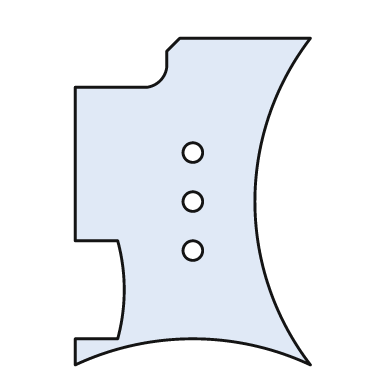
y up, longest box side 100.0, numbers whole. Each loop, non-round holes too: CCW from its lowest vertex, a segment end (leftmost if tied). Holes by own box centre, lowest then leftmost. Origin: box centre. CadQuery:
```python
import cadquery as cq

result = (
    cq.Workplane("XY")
    .moveTo(-36.0, -50.0)
    .threePointArc((0.0, -42.0), (36.0, -50.0))
    .threePointArc((19.0, 0.0), (36.0, 50.0))
    .lineTo(-4.0, 50.0)
    .lineTo(-8.0, 46.0)
    .lineTo(-8.0, 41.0)
    .threePointArc((-10.0, 37.0), (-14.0, 35.0))
    .lineTo(-36.0, 35.0)
    .lineTo(-36.0, -12.0)
    .lineTo(-23.0, -12.0)
    .threePointArc((-21.0, -27.0), (-23.0, -42.0))
    .lineTo(-36.0, -42.0)
    .close()
    .moveTo(0.0, -15.0)
    .circle(3.0)
    .moveTo(0.0, 0.0)
    .circle(3.0)
    .moveTo(0.0, 15.0)
    .circle(3.0)
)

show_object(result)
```